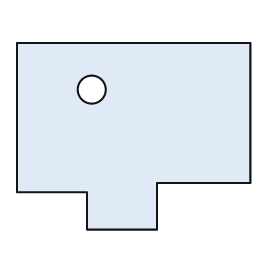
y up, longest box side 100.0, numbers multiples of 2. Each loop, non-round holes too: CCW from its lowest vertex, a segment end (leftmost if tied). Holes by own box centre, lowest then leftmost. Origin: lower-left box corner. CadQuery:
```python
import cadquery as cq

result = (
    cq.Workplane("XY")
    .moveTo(30.0, 0.0)
    .lineTo(60.0, 0.0)
    .lineTo(60.0, 20.0)
    .lineTo(100.0, 20.0)
    .lineTo(100.0, 80.0)
    .lineTo(0.0, 80.0)
    .lineTo(0.0, 16.0)
    .lineTo(30.0, 16.0)
    .close()
    .moveTo(32.0, 60.0)
    .circle(6.0)
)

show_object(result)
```